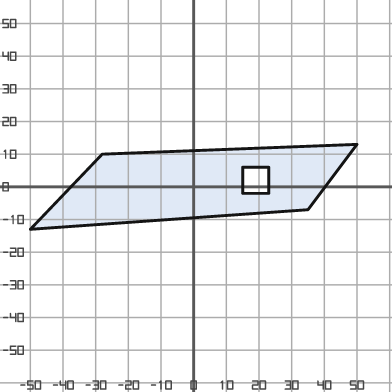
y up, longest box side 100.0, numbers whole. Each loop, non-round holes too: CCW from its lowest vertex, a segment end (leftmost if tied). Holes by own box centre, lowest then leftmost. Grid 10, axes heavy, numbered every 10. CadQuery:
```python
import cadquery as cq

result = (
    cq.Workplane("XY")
    .moveTo(-50.0, -13.0)
    .lineTo(35.0, -7.0)
    .lineTo(50.0, 13.0)
    .lineTo(-28.0, 10.0)
    .close()
    .moveTo(15.0, -2.0)
    .lineTo(23.0, -2.0)
    .lineTo(23.0, 6.0)
    .lineTo(15.0, 6.0)
    .close()
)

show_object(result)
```